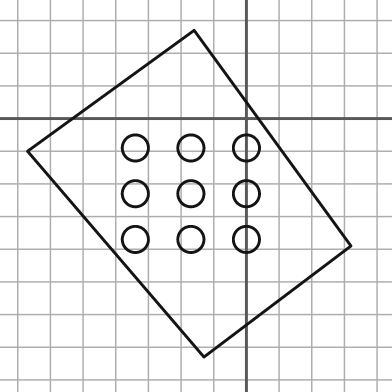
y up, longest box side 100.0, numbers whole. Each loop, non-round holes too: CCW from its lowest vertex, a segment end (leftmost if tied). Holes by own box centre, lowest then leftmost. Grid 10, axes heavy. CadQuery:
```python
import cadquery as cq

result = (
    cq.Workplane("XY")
    .moveTo(-13.0, -73.0)
    .lineTo(32.0, -39.0)
    .lineTo(-16.0, 27.0)
    .lineTo(-67.0, -10.0)
    .close()
    .moveTo(-34.0, -37.0)
    .circle(4.0)
    .moveTo(-17.0, -37.0)
    .circle(4.0)
    .moveTo(0.0, -37.0)
    .circle(4.0)
    .moveTo(-34.0, -23.0)
    .circle(4.0)
    .moveTo(-17.0, -23.0)
    .circle(4.0)
    .moveTo(0.0, -23.0)
    .circle(4.0)
    .moveTo(-34.0, -9.0)
    .circle(4.0)
    .moveTo(-17.0, -9.0)
    .circle(4.0)
    .moveTo(0.0, -9.0)
    .circle(4.0)
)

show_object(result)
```